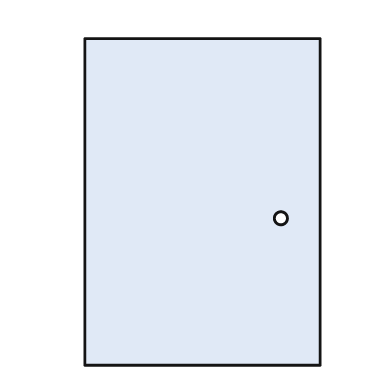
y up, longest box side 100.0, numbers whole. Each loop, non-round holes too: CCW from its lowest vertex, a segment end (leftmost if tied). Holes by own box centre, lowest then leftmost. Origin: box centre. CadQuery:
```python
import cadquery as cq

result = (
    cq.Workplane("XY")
    .moveTo(-36.0, -50.0)
    .lineTo(36.0, -50.0)
    .lineTo(36.0, 50.0)
    .lineTo(-36.0, 50.0)
    .close()
    .moveTo(24.0, -5.0)
    .circle(2.0)
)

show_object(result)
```